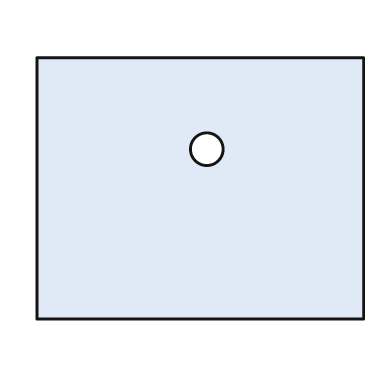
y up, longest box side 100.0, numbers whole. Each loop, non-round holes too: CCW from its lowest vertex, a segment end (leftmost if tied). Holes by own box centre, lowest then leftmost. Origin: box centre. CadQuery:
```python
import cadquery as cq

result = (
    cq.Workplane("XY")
    .moveTo(-50.0, -40.0)
    .lineTo(50.0, -40.0)
    .lineTo(50.0, 40.0)
    .lineTo(-50.0, 40.0)
    .close()
    .moveTo(2.0, 12.0)
    .circle(5.0)
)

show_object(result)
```